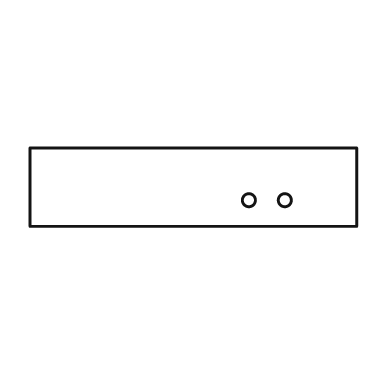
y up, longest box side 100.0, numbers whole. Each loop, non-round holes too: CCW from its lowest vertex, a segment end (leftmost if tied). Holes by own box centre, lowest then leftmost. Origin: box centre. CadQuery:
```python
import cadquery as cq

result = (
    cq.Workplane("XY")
    .moveTo(-50.0, -12.0)
    .lineTo(50.0, -12.0)
    .lineTo(50.0, 12.0)
    .lineTo(-50.0, 12.0)
    .close()
    .moveTo(17.0, -4.0)
    .circle(2.0)
    .moveTo(28.0, -4.0)
    .circle(2.0)
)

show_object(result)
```